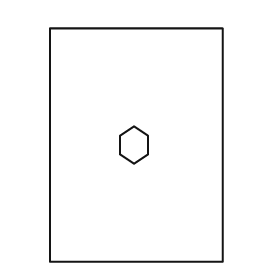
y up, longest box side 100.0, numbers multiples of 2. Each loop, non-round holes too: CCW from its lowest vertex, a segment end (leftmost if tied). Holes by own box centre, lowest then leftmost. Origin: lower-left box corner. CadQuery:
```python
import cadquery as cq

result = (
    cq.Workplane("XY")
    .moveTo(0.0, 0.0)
    .lineTo(74.0, 0.0)
    .lineTo(74.0, 100.0)
    .lineTo(0.0, 100.0)
    .close()
    .moveTo(36.0, 42.0)
    .lineTo(42.0, 46.0)
    .lineTo(42.0, 54.0)
    .lineTo(36.0, 58.0)
    .lineTo(30.0, 54.0)
    .lineTo(30.0, 46.0)
    .close()
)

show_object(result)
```